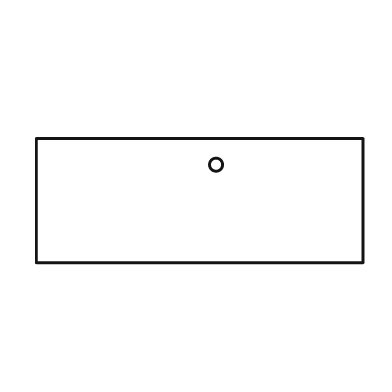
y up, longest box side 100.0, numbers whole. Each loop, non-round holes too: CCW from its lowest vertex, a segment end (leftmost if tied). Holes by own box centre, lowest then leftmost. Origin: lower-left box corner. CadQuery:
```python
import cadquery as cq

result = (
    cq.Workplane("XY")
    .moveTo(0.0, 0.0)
    .lineTo(100.0, 0.0)
    .lineTo(100.0, 38.0)
    .lineTo(0.0, 38.0)
    .close()
    .moveTo(55.0, 30.0)
    .circle(2.0)
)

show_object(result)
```